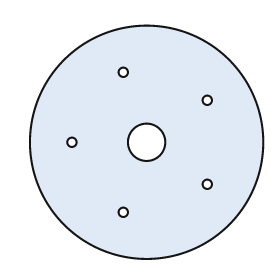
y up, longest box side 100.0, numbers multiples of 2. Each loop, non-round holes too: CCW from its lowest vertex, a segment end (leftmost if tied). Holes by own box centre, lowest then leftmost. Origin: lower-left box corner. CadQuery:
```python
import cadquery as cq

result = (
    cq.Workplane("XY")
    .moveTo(50.0, 50.0)
    .circle(50.0)
    .moveTo(40.0, 20.0)
    .circle(2.0)
    .moveTo(76.0, 32.0)
    .circle(2.0)
    .moveTo(18.0, 50.0)
    .circle(2.0)
    .moveTo(50.0, 50.0)
    .circle(8.0)
    .moveTo(76.0, 68.0)
    .circle(2.0)
    .moveTo(40.0, 80.0)
    .circle(2.0)
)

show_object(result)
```